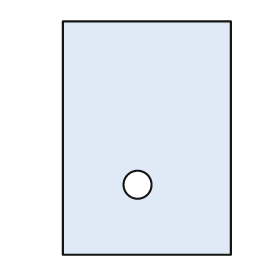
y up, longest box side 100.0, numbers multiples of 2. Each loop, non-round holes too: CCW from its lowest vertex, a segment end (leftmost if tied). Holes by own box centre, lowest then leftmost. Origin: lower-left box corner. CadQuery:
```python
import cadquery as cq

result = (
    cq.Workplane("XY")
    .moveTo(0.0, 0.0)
    .lineTo(72.0, 0.0)
    .lineTo(72.0, 100.0)
    .lineTo(0.0, 100.0)
    .close()
    .moveTo(32.0, 30.0)
    .circle(6.0)
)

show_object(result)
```